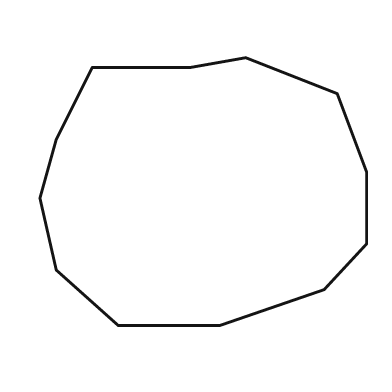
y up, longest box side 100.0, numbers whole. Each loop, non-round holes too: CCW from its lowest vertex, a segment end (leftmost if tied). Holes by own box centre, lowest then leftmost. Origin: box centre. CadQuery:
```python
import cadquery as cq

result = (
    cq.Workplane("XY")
    .moveTo(-26.0, -41.0)
    .lineTo(5.0, -41.0)
    .lineTo(37.0, -30.0)
    .lineTo(50.0, -16.0)
    .lineTo(50.0, 6.0)
    .lineTo(41.0, 30.0)
    .lineTo(13.0, 41.0)
    .lineTo(-4.0, 38.0)
    .lineTo(-34.0, 38.0)
    .lineTo(-45.0, 16.0)
    .lineTo(-50.0, -2.0)
    .lineTo(-45.0, -24.0)
    .close()
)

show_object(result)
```